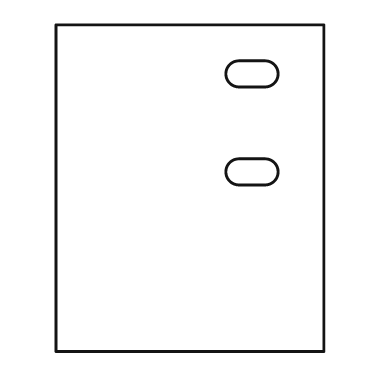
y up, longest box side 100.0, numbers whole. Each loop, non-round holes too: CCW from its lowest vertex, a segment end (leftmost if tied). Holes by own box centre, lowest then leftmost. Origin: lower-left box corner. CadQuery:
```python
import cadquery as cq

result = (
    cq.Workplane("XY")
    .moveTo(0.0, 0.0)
    .lineTo(82.0, 0.0)
    .lineTo(82.0, 100.0)
    .lineTo(0.0, 100.0)
    .close()
    .moveTo(56.0, 51.0)
    .lineTo(64.0, 51.0)
    .threePointArc((68.0, 55.0), (64.0, 59.0))
    .lineTo(56.0, 59.0)
    .threePointArc((52.0, 55.0), (56.0, 51.0))
    .close()
    .moveTo(56.0, 81.0)
    .lineTo(64.0, 81.0)
    .threePointArc((68.0, 85.0), (64.0, 89.0))
    .lineTo(56.0, 89.0)
    .threePointArc((52.0, 85.0), (56.0, 81.0))
    .close()
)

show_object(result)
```